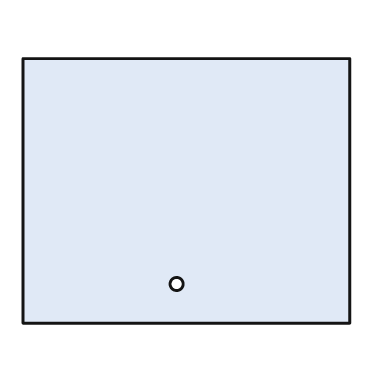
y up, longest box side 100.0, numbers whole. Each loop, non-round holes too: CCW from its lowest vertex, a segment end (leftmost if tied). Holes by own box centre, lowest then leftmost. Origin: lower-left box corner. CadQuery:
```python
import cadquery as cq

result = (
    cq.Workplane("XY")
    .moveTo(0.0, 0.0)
    .lineTo(100.0, 0.0)
    .lineTo(100.0, 81.0)
    .lineTo(0.0, 81.0)
    .close()
    .moveTo(47.0, 12.0)
    .circle(2.0)
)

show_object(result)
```